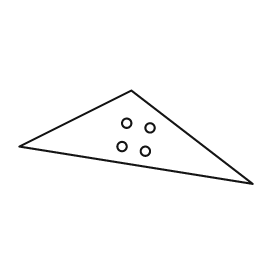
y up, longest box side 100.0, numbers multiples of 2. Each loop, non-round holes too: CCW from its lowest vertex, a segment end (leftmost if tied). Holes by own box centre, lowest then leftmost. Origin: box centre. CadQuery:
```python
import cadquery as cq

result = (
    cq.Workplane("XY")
    .moveTo(50.0, -20.0)
    .lineTo(-2.0, 20.0)
    .lineTo(-50.0, -4.0)
    .close()
    .moveTo(4.0, -6.0)
    .circle(2.0)
    .moveTo(-6.0, -4.0)
    .circle(2.0)
    .moveTo(6.0, 4.0)
    .circle(2.0)
    .moveTo(-4.0, 6.0)
    .circle(2.0)
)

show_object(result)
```